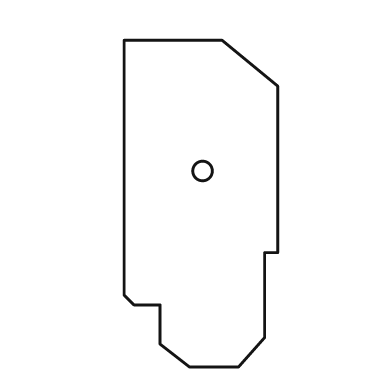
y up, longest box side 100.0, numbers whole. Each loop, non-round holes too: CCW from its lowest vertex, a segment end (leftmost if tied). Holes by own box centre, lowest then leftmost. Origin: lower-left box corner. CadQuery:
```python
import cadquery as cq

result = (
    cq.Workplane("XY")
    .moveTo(20.0, 0.0)
    .lineTo(35.0, 0.0)
    .lineTo(43.0, 9.0)
    .lineTo(43.0, 35.0)
    .lineTo(47.0, 35.0)
    .lineTo(47.0, 86.0)
    .lineTo(30.0, 100.0)
    .lineTo(0.0, 100.0)
    .lineTo(0.0, 22.0)
    .lineTo(3.0, 19.0)
    .lineTo(11.0, 19.0)
    .lineTo(11.0, 7.0)
    .close()
    .moveTo(24.0, 60.0)
    .circle(3.0)
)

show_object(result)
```